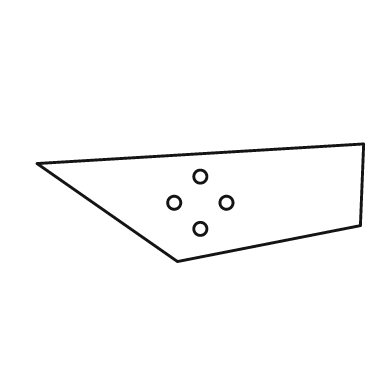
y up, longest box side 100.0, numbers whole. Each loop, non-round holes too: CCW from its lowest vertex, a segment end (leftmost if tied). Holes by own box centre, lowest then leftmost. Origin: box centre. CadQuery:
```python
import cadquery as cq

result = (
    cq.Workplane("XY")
    .moveTo(-7.0, -18.0)
    .lineTo(49.0, -7.0)
    .lineTo(50.0, 18.0)
    .lineTo(-50.0, 12.0)
    .close()
    .moveTo(0.0, -8.0)
    .circle(2.0)
    .moveTo(-8.0, 0.0)
    .circle(2.0)
    .moveTo(8.0, 0.0)
    .circle(2.0)
    .moveTo(0.0, 8.0)
    .circle(2.0)
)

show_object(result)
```